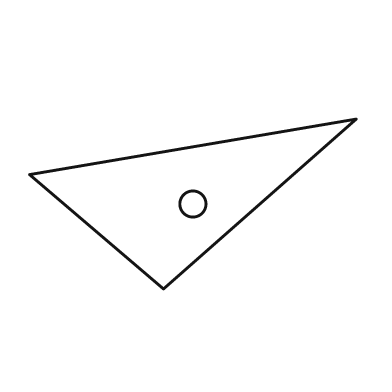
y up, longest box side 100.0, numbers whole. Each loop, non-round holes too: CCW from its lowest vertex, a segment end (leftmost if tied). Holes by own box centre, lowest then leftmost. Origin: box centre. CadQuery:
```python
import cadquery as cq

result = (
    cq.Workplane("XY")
    .moveTo(-9.0, -26.0)
    .lineTo(50.0, 26.0)
    .lineTo(-50.0, 9.0)
    .close()
    .moveTo(0.0, 0.0)
    .circle(4.0)
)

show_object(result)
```